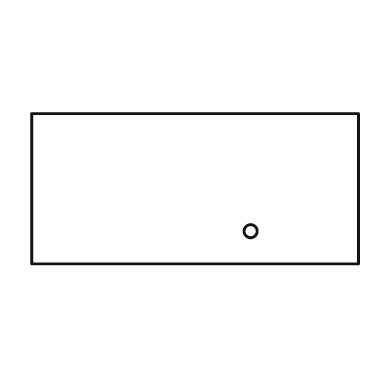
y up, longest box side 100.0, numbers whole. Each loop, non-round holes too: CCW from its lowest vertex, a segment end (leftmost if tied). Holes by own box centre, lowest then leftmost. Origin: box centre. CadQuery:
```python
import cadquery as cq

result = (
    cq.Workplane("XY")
    .moveTo(-50.0, -23.0)
    .lineTo(50.0, -23.0)
    .lineTo(50.0, 23.0)
    .lineTo(-50.0, 23.0)
    .close()
    .moveTo(17.0, -13.0)
    .circle(2.0)
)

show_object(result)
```